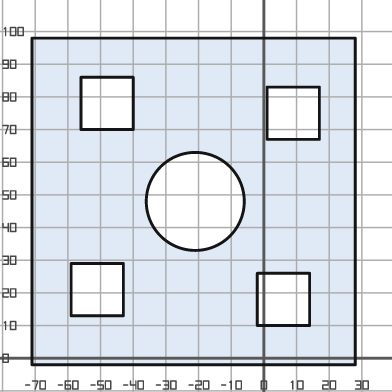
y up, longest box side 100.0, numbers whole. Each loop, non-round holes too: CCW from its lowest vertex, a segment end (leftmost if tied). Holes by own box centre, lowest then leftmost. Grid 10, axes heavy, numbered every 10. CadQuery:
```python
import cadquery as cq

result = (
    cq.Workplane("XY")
    .moveTo(-71.0, -2.0)
    .lineTo(28.0, -2.0)
    .lineTo(28.0, 98.0)
    .lineTo(-71.0, 98.0)
    .close()
    .moveTo(-2.0, 10.0)
    .lineTo(14.0, 10.0)
    .lineTo(14.0, 26.0)
    .lineTo(-2.0, 26.0)
    .close()
    .moveTo(-59.0, 13.0)
    .lineTo(-43.0, 13.0)
    .lineTo(-43.0, 29.0)
    .lineTo(-59.0, 29.0)
    .close()
    .moveTo(-21.0, 48.0)
    .circle(15.0)
    .moveTo(1.0, 67.0)
    .lineTo(17.0, 67.0)
    .lineTo(17.0, 83.0)
    .lineTo(1.0, 83.0)
    .close()
    .moveTo(-56.0, 70.0)
    .lineTo(-40.0, 70.0)
    .lineTo(-40.0, 86.0)
    .lineTo(-56.0, 86.0)
    .close()
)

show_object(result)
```